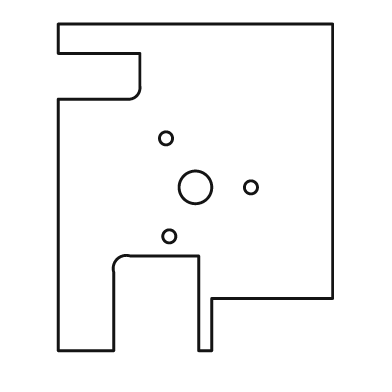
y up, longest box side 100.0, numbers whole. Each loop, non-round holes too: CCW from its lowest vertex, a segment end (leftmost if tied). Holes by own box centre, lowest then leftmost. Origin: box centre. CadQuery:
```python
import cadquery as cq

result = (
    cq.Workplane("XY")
    .moveTo(-42.0, -50.0)
    .lineTo(-25.0, -50.0)
    .lineTo(-25.0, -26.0)
    .threePointArc((-24.0, -22.0), (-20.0, -21.0))
    .lineTo(1.0, -21.0)
    .lineTo(1.0, -50.0)
    .lineTo(5.0, -50.0)
    .lineTo(5.0, -34.0)
    .lineTo(42.0, -34.0)
    .lineTo(42.0, 50.0)
    .lineTo(-42.0, 50.0)
    .lineTo(-42.0, 41.0)
    .lineTo(-17.0, 41.0)
    .lineTo(-17.0, 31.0)
    .threePointArc((-18.0, 28.0), (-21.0, 27.0))
    .lineTo(-42.0, 27.0)
    .close()
    .moveTo(-8.0, -15.0)
    .circle(2.0)
    .moveTo(0.0, 0.0)
    .circle(5.0)
    .moveTo(17.0, 0.0)
    .circle(2.0)
    .moveTo(-9.0, 15.0)
    .circle(2.0)
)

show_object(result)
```